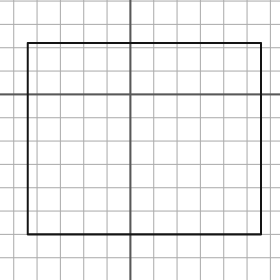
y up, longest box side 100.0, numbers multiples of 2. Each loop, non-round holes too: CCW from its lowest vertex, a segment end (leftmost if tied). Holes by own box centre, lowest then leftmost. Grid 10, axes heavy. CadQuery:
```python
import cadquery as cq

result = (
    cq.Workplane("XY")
    .moveTo(-44.0, -60.0)
    .lineTo(56.0, -60.0)
    .lineTo(56.0, 22.0)
    .lineTo(-44.0, 22.0)
    .close()
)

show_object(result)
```